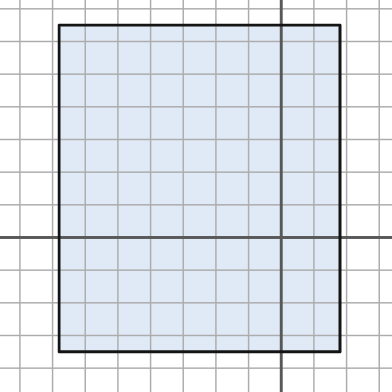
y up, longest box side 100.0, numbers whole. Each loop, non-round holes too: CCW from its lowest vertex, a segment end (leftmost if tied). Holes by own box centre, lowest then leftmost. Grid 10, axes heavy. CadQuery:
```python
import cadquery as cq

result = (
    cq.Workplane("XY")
    .moveTo(-68.0, -35.0)
    .lineTo(18.0, -35.0)
    .lineTo(18.0, 65.0)
    .lineTo(-68.0, 65.0)
    .close()
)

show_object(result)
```